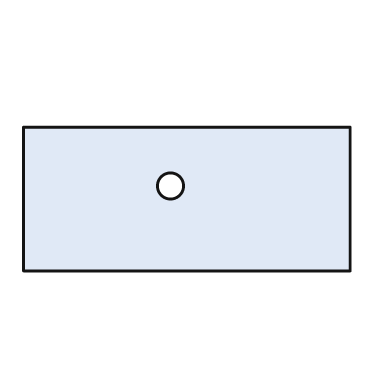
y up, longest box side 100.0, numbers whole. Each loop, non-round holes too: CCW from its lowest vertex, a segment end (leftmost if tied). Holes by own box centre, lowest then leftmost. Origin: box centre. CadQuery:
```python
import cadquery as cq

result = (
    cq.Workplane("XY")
    .moveTo(-50.0, -22.0)
    .lineTo(50.0, -22.0)
    .lineTo(50.0, 22.0)
    .lineTo(-50.0, 22.0)
    .close()
    .moveTo(-5.0, 4.0)
    .circle(4.0)
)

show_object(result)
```